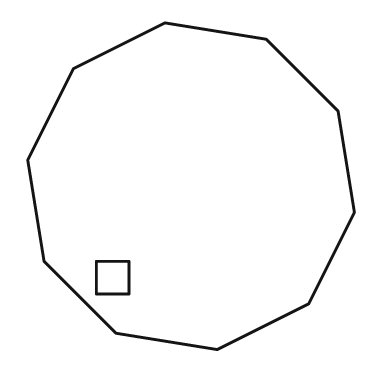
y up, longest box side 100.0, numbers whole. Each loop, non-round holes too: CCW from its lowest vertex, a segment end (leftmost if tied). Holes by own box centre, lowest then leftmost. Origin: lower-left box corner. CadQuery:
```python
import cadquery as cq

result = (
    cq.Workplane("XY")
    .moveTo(58.0, 0.0)
    .lineTo(86.0, 14.0)
    .lineTo(100.0, 42.0)
    .lineTo(95.0, 73.0)
    .lineTo(73.0, 95.0)
    .lineTo(42.0, 100.0)
    .lineTo(14.0, 86.0)
    .lineTo(0.0, 58.0)
    .lineTo(5.0, 27.0)
    .lineTo(27.0, 5.0)
    .close()
    .moveTo(21.0, 17.0)
    .lineTo(31.0, 17.0)
    .lineTo(31.0, 27.0)
    .lineTo(21.0, 27.0)
    .close()
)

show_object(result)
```